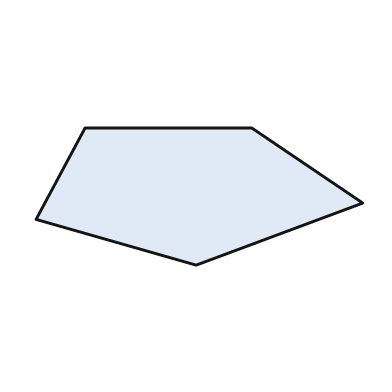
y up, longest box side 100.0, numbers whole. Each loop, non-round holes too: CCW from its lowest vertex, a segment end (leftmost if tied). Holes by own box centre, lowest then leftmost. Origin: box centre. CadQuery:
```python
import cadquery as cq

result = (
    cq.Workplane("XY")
    .moveTo(-1.0, -21.0)
    .lineTo(50.0, -2.0)
    .lineTo(16.0, 21.0)
    .lineTo(-35.0, 21.0)
    .lineTo(-50.0, -7.0)
    .close()
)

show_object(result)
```